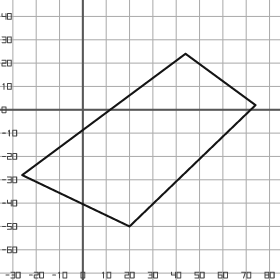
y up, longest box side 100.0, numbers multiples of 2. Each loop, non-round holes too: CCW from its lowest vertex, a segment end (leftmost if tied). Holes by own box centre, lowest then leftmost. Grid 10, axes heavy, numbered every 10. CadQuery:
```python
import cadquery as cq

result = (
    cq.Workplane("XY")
    .moveTo(20.0, -50.0)
    .lineTo(74.0, 2.0)
    .lineTo(44.0, 24.0)
    .lineTo(-26.0, -28.0)
    .close()
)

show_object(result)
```